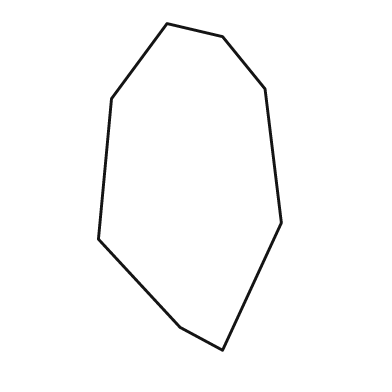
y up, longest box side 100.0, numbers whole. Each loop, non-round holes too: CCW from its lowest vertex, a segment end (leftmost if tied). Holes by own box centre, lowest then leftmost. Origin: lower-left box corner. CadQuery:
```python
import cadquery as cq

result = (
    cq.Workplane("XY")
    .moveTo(38.0, 0.0)
    .lineTo(56.0, 39.0)
    .lineTo(51.0, 80.0)
    .lineTo(38.0, 96.0)
    .lineTo(21.0, 100.0)
    .lineTo(4.0, 77.0)
    .lineTo(0.0, 34.0)
    .lineTo(25.0, 7.0)
    .close()
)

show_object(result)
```